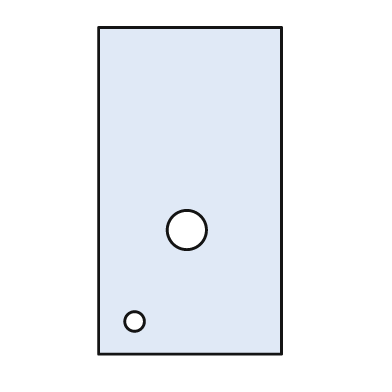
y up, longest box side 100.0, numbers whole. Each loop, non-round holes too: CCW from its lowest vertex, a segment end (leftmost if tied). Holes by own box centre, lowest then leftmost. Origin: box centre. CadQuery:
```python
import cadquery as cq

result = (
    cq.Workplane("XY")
    .moveTo(-28.0, -50.0)
    .lineTo(28.0, -50.0)
    .lineTo(28.0, 50.0)
    .lineTo(-28.0, 50.0)
    .close()
    .moveTo(-17.0, -40.0)
    .circle(3.0)
    .moveTo(-1.0, -12.0)
    .circle(6.0)
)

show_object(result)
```